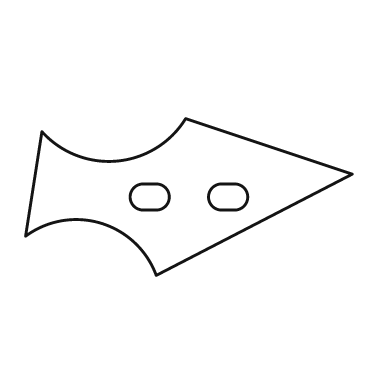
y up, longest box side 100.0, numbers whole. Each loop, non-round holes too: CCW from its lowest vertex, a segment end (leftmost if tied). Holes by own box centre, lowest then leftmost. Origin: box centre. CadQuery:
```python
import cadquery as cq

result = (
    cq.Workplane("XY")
    .moveTo(-10.0, -24.0)
    .lineTo(50.0, 7.0)
    .lineTo(-1.0, 24.0)
    .threePointArc((-22.0, 11.0), (-45.0, 20.0))
    .lineTo(-50.0, -12.0)
    .threePointArc((-27.0, -8.0), (-10.0, -24.0))
    .close()
    .moveTo(-14.0, -4.0)
    .lineTo(-10.0, -4.0)
    .threePointArc((-6.0, 0.0), (-10.0, 4.0))
    .lineTo(-14.0, 4.0)
    .threePointArc((-18.0, 0.0), (-14.0, -4.0))
    .close()
    .moveTo(10.0, -4.0)
    .lineTo(14.0, -4.0)
    .threePointArc((18.0, 0.0), (14.0, 4.0))
    .lineTo(10.0, 4.0)
    .threePointArc((6.0, 0.0), (10.0, -4.0))
    .close()
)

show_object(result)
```